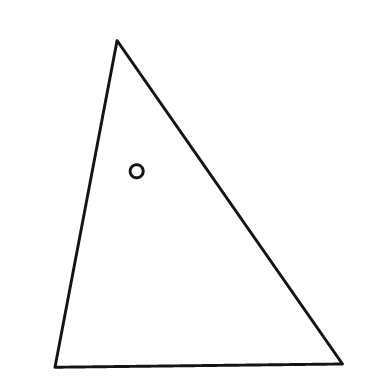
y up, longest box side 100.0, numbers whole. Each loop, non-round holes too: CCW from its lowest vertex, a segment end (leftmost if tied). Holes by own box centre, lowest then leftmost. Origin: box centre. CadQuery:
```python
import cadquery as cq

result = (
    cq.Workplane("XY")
    .moveTo(-44.0, -50.0)
    .lineTo(44.0, -49.0)
    .lineTo(-25.0, 50.0)
    .close()
    .moveTo(-19.0, 10.0)
    .circle(2.0)
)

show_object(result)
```